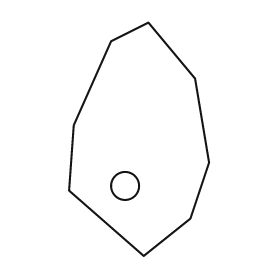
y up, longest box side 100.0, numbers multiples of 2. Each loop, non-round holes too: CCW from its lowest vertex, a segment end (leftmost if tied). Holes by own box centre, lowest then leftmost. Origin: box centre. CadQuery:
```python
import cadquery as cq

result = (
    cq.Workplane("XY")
    .moveTo(2.0, -50.0)
    .lineTo(22.0, -34.0)
    .lineTo(30.0, -10.0)
    .lineTo(24.0, 26.0)
    .lineTo(4.0, 50.0)
    .lineTo(-12.0, 42.0)
    .lineTo(-28.0, 6.0)
    .lineTo(-30.0, -22.0)
    .close()
    .moveTo(-6.0, -20.0)
    .circle(6.0)
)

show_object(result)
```